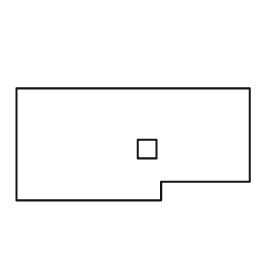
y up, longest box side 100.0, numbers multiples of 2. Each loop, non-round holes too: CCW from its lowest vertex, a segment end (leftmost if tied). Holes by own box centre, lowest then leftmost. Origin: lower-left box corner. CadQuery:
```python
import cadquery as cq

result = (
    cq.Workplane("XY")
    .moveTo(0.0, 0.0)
    .lineTo(62.0, 0.0)
    .lineTo(62.0, 8.0)
    .lineTo(100.0, 8.0)
    .lineTo(100.0, 48.0)
    .lineTo(0.0, 48.0)
    .close()
    .moveTo(52.0, 18.0)
    .lineTo(60.0, 18.0)
    .lineTo(60.0, 26.0)
    .lineTo(52.0, 26.0)
    .close()
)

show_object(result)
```